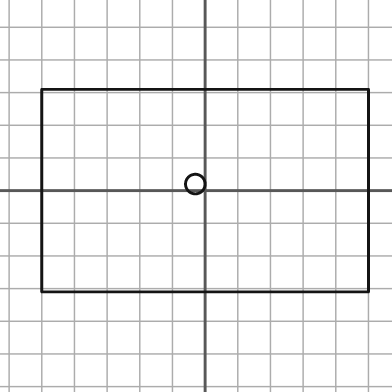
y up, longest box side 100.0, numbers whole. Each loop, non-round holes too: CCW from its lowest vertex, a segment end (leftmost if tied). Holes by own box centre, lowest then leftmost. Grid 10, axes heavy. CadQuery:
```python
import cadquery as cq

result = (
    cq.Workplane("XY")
    .moveTo(-50.0, -31.0)
    .lineTo(50.0, -31.0)
    .lineTo(50.0, 31.0)
    .lineTo(-50.0, 31.0)
    .close()
    .moveTo(-3.0, 2.0)
    .circle(3.0)
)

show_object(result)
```